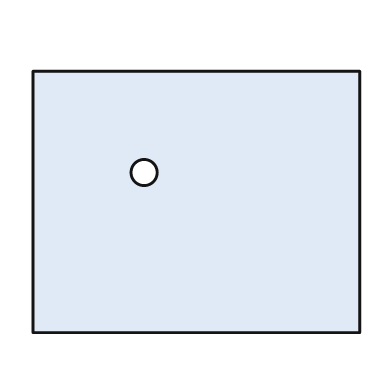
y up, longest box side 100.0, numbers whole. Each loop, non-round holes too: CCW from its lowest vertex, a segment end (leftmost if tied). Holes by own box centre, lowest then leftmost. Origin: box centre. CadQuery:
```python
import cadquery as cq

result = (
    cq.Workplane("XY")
    .moveTo(-50.0, -40.0)
    .lineTo(50.0, -40.0)
    .lineTo(50.0, 40.0)
    .lineTo(-50.0, 40.0)
    .close()
    .moveTo(-16.0, 9.0)
    .circle(4.0)
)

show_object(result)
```